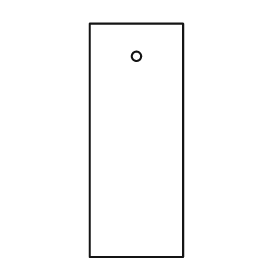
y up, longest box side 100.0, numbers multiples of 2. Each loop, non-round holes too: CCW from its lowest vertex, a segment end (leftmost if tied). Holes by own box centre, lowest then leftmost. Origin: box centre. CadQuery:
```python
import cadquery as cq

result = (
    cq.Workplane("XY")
    .moveTo(-20.0, -50.0)
    .lineTo(20.0, -50.0)
    .lineTo(20.0, 50.0)
    .lineTo(-20.0, 50.0)
    .close()
    .moveTo(0.0, 36.0)
    .circle(2.0)
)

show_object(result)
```